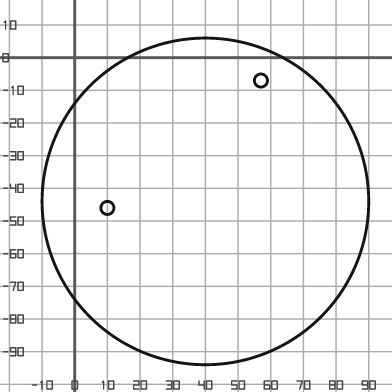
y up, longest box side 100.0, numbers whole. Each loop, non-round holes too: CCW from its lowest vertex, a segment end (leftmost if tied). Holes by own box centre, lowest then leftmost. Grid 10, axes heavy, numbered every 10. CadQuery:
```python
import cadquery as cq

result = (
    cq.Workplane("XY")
    .moveTo(40.0, -44.0)
    .circle(50.0)
    .moveTo(10.0, -46.0)
    .circle(2.0)
    .moveTo(57.0, -7.0)
    .circle(2.0)
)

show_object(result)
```